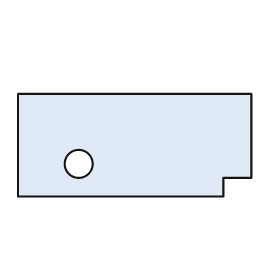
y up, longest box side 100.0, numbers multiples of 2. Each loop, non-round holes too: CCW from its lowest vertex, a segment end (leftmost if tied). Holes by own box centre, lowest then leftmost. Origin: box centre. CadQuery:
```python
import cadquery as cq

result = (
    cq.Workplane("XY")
    .moveTo(-50.0, -22.0)
    .lineTo(38.0, -22.0)
    .lineTo(38.0, -14.0)
    .lineTo(50.0, -14.0)
    .lineTo(50.0, 22.0)
    .lineTo(-50.0, 22.0)
    .close()
    .moveTo(-24.0, -8.0)
    .circle(6.0)
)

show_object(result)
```